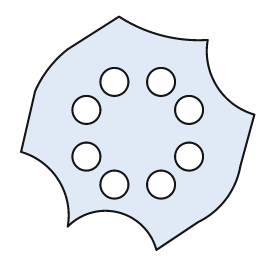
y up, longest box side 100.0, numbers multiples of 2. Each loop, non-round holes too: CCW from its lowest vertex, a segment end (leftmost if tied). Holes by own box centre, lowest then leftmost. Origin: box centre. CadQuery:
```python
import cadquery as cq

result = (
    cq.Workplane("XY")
    .moveTo(8.0, -50.0)
    .lineTo(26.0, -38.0)
    .threePointArc((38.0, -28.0), (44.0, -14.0))
    .lineTo(50.0, 8.0)
    .threePointArc((34.0, 20.0), (30.0, 40.0))
    .threePointArc((10.0, 42.0), (-8.0, 50.0))
    .lineTo(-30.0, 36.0)
    .threePointArc((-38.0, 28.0), (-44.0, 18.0))
    .lineTo(-50.0, -8.0)
    .threePointArc((-34.0, -20.0), (-30.0, -40.0))
    .threePointArc((-8.0, -34.0), (8.0, -50.0))
    .close()
    .moveTo(-10.0, -22.0)
    .circle(6.0)
    .moveTo(10.0, -22.0)
    .circle(6.0)
    .moveTo(-22.0, -10.0)
    .circle(6.0)
    .moveTo(22.0, -10.0)
    .circle(6.0)
    .moveTo(-22.0, 10.0)
    .circle(6.0)
    .moveTo(22.0, 10.0)
    .circle(6.0)
    .moveTo(-10.0, 22.0)
    .circle(6.0)
    .moveTo(10.0, 22.0)
    .circle(6.0)
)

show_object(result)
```